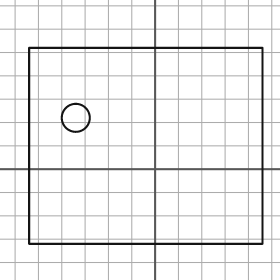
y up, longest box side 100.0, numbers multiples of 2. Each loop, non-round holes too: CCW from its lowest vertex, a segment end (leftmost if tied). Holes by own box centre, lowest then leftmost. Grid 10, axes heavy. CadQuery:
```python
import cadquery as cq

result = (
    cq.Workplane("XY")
    .moveTo(-54.0, -32.0)
    .lineTo(46.0, -32.0)
    .lineTo(46.0, 52.0)
    .lineTo(-54.0, 52.0)
    .close()
    .moveTo(-34.0, 22.0)
    .circle(6.0)
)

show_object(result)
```